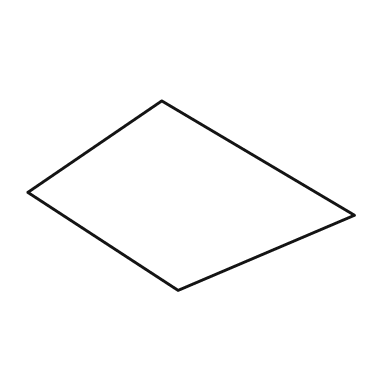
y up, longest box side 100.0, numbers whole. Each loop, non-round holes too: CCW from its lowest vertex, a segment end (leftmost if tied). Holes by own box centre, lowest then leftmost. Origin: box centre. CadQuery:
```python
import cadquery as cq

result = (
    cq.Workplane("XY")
    .moveTo(-4.0, -29.0)
    .lineTo(50.0, -6.0)
    .lineTo(-9.0, 29.0)
    .lineTo(-50.0, 1.0)
    .close()
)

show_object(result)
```